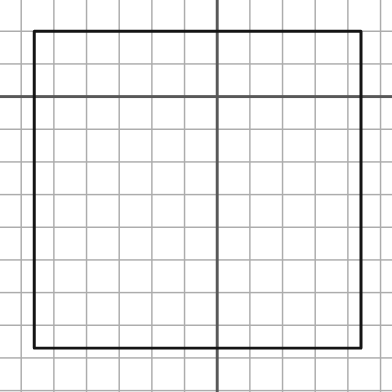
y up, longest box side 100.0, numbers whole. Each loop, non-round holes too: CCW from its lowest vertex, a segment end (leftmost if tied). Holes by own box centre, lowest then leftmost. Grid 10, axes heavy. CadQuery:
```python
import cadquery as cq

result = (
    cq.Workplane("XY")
    .moveTo(-56.0, -77.0)
    .lineTo(44.0, -77.0)
    .lineTo(44.0, 20.0)
    .lineTo(-56.0, 20.0)
    .close()
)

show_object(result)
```